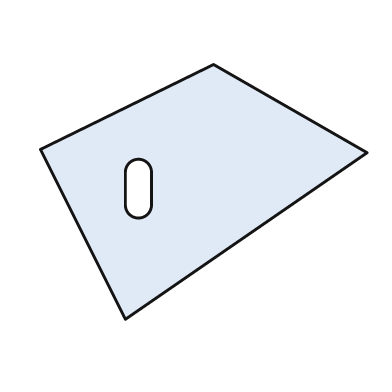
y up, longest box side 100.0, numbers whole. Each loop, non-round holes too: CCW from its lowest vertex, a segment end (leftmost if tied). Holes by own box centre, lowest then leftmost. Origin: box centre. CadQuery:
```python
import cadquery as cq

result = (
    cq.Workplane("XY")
    .moveTo(-24.0, -39.0)
    .lineTo(50.0, 12.0)
    .lineTo(3.0, 39.0)
    .lineTo(-50.0, 13.0)
    .close()
    .moveTo(-24.0, -4.0)
    .threePointArc((-20.0, -8.0), (-16.0, -4.0))
    .lineTo(-16.0, 6.0)
    .threePointArc((-20.0, 10.0), (-24.0, 6.0))
    .close()
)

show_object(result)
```